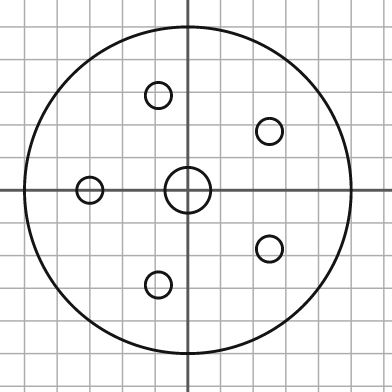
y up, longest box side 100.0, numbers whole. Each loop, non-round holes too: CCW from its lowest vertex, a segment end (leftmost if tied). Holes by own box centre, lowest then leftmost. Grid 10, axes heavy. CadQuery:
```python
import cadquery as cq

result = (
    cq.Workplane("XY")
    .moveTo(0.0, 0.0)
    .circle(50.0)
    .moveTo(-9.0, -29.0)
    .circle(4.0)
    .moveTo(25.0, -18.0)
    .circle(4.0)
    .moveTo(-30.0, 0.0)
    .circle(4.0)
    .moveTo(0.0, 0.0)
    .circle(7.0)
    .moveTo(25.0, 18.0)
    .circle(4.0)
    .moveTo(-9.0, 29.0)
    .circle(4.0)
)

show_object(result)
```